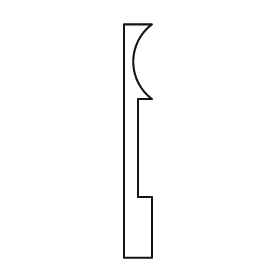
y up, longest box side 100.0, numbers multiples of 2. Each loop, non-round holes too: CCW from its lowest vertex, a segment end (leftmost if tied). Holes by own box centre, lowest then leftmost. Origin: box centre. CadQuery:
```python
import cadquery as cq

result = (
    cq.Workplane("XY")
    .moveTo(-6.0, -50.0)
    .lineTo(6.0, -50.0)
    .lineTo(6.0, -24.0)
    .lineTo(0.0, -24.0)
    .lineTo(0.0, 18.0)
    .lineTo(6.0, 18.0)
    .threePointArc((-2.0, 34.0), (6.0, 50.0))
    .lineTo(-6.0, 50.0)
    .close()
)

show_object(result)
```